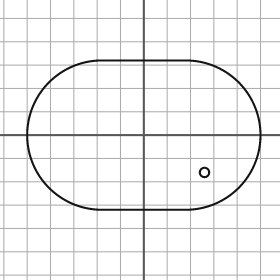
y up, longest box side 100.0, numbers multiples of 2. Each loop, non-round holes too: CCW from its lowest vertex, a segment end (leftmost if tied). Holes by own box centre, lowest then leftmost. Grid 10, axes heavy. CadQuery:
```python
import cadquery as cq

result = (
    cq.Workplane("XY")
    .moveTo(-18.0, -32.0)
    .lineTo(18.0, -32.0)
    .threePointArc((50.0, 0.0), (18.0, 32.0))
    .lineTo(-18.0, 32.0)
    .threePointArc((-50.0, 0.0), (-18.0, -32.0))
    .close()
    .moveTo(26.0, -16.0)
    .circle(2.0)
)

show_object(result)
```